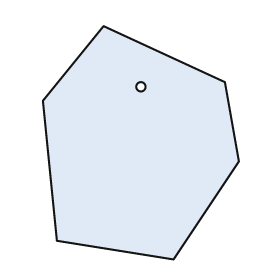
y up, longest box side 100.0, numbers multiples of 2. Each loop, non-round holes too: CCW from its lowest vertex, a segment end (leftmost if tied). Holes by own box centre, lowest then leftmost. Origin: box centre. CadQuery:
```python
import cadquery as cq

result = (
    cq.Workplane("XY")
    .moveTo(14.0, -50.0)
    .lineTo(42.0, -8.0)
    .lineTo(36.0, 26.0)
    .lineTo(-16.0, 50.0)
    .lineTo(-42.0, 18.0)
    .lineTo(-36.0, -42.0)
    .close()
    .moveTo(0.0, 24.0)
    .circle(2.0)
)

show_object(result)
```